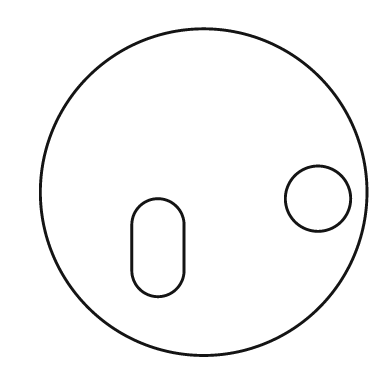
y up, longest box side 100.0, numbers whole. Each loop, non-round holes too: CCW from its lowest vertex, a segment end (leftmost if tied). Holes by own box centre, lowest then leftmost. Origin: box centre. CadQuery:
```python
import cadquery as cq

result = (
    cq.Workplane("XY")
    .moveTo(0.0, 0.0)
    .circle(50.0)
    .moveTo(-22.0, -24.0)
    .threePointArc((-14.0, -32.0), (-6.0, -24.0))
    .lineTo(-6.0, -10.0)
    .threePointArc((-14.0, -2.0), (-22.0, -10.0))
    .close()
    .moveTo(35.0, -2.0)
    .circle(10.0)
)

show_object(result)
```